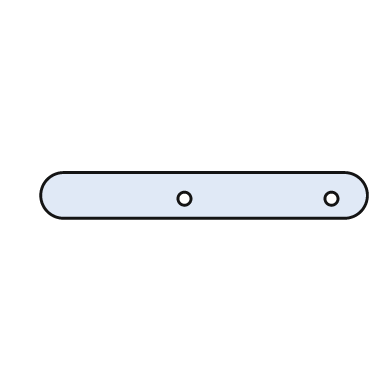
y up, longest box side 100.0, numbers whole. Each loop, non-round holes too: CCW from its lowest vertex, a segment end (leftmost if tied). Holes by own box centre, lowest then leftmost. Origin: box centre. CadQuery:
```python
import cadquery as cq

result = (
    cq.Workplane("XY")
    .moveTo(-43.0, -7.0)
    .lineTo(43.0, -7.0)
    .threePointArc((50.0, 0.0), (43.0, 7.0))
    .lineTo(-43.0, 7.0)
    .threePointArc((-50.0, 0.0), (-43.0, -7.0))
    .close()
    .moveTo(-6.0, -1.0)
    .circle(2.0)
    .moveTo(39.0, -1.0)
    .circle(2.0)
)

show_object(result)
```